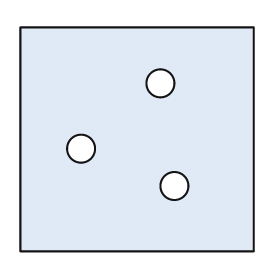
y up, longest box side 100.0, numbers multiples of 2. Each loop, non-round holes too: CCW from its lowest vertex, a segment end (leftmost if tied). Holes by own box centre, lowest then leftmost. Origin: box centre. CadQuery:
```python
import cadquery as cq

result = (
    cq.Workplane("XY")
    .moveTo(-50.0, -48.0)
    .lineTo(50.0, -48.0)
    .lineTo(50.0, 48.0)
    .lineTo(-50.0, 48.0)
    .close()
    .moveTo(16.0, -20.0)
    .circle(6.0)
    .moveTo(-24.0, -4.0)
    .circle(6.0)
    .moveTo(10.0, 24.0)
    .circle(6.0)
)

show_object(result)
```